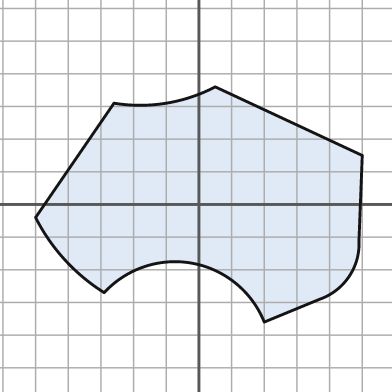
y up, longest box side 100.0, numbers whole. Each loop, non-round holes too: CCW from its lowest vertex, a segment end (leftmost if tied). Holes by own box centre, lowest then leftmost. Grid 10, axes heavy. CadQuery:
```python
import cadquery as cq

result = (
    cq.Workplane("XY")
    .moveTo(20.0, -36.0)
    .lineTo(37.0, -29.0)
    .threePointArc((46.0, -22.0), (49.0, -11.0))
    .lineTo(50.0, 15.0)
    .lineTo(5.0, 36.0)
    .threePointArc((-10.0, 31.0), (-26.0, 31.0))
    .lineTo(-50.0, -4.0)
    .threePointArc((-41.0, -17.0), (-29.0, -27.0))
    .threePointArc((-2.0, -18.0), (20.0, -36.0))
    .close()
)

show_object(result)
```